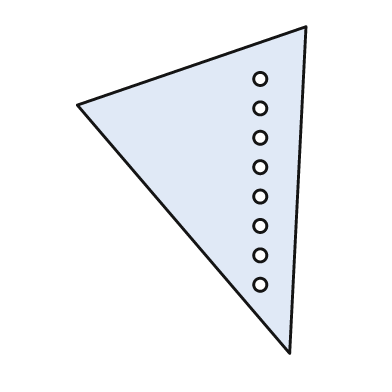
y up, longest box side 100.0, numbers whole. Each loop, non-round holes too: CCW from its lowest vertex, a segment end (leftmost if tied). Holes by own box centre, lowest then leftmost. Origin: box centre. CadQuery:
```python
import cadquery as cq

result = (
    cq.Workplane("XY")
    .moveTo(30.0, -50.0)
    .lineTo(35.0, 50.0)
    .lineTo(-35.0, 26.0)
    .close()
    .moveTo(21.0, -29.0)
    .circle(2.0)
    .moveTo(21.0, -20.0)
    .circle(2.0)
    .moveTo(21.0, -11.0)
    .circle(2.0)
    .moveTo(21.0, -2.0)
    .circle(2.0)
    .moveTo(21.0, 7.0)
    .circle(2.0)
    .moveTo(21.0, 16.0)
    .circle(2.0)
    .moveTo(21.0, 25.0)
    .circle(2.0)
    .moveTo(21.0, 34.0)
    .circle(2.0)
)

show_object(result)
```